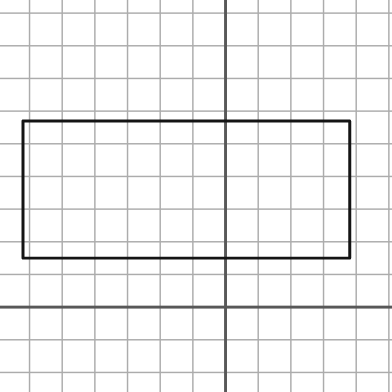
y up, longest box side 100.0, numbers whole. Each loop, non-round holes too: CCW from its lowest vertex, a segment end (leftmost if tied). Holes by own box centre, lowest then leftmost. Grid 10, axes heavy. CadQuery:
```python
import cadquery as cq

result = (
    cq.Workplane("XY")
    .moveTo(-62.0, 15.0)
    .lineTo(38.0, 15.0)
    .lineTo(38.0, 57.0)
    .lineTo(-62.0, 57.0)
    .close()
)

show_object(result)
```